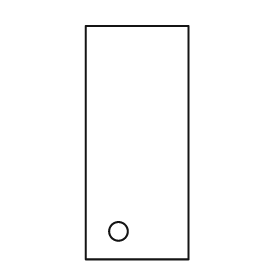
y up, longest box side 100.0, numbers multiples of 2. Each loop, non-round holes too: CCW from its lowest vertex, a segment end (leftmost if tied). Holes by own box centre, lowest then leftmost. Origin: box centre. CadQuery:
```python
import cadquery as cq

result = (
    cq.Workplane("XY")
    .moveTo(-22.0, -50.0)
    .lineTo(22.0, -50.0)
    .lineTo(22.0, 50.0)
    .lineTo(-22.0, 50.0)
    .close()
    .moveTo(-8.0, -38.0)
    .circle(4.0)
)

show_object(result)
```